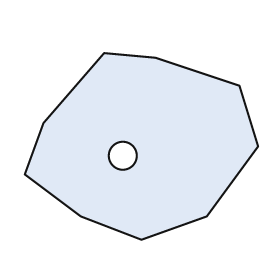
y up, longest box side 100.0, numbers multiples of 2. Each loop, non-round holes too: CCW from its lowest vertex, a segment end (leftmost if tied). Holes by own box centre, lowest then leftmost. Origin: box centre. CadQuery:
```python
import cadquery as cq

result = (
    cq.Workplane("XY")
    .moveTo(0.0, -40.0)
    .lineTo(28.0, -30.0)
    .lineTo(50.0, 0.0)
    .lineTo(42.0, 26.0)
    .lineTo(6.0, 38.0)
    .lineTo(-16.0, 40.0)
    .lineTo(-42.0, 10.0)
    .lineTo(-50.0, -12.0)
    .lineTo(-26.0, -30.0)
    .close()
    .moveTo(-8.0, -4.0)
    .circle(6.0)
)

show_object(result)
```